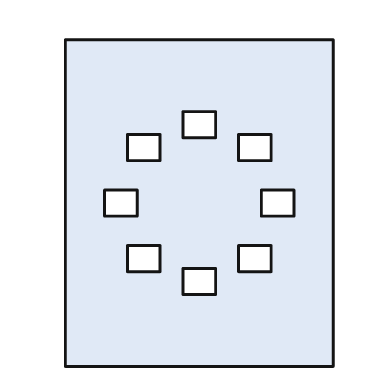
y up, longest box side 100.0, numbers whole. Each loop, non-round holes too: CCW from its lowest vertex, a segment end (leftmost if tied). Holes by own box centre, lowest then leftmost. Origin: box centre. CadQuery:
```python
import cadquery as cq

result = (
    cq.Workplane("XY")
    .moveTo(-41.0, -50.0)
    .lineTo(41.0, -50.0)
    .lineTo(41.0, 50.0)
    .lineTo(-41.0, 50.0)
    .close()
    .moveTo(-5.0, -28.0)
    .lineTo(5.0, -28.0)
    .lineTo(5.0, -20.0)
    .lineTo(-5.0, -20.0)
    .close()
    .moveTo(-22.0, -21.0)
    .lineTo(-12.0, -21.0)
    .lineTo(-12.0, -13.0)
    .lineTo(-22.0, -13.0)
    .close()
    .moveTo(12.0, -21.0)
    .lineTo(22.0, -21.0)
    .lineTo(22.0, -13.0)
    .lineTo(12.0, -13.0)
    .close()
    .moveTo(-29.0, -4.0)
    .lineTo(-19.0, -4.0)
    .lineTo(-19.0, 4.0)
    .lineTo(-29.0, 4.0)
    .close()
    .moveTo(19.0, -4.0)
    .lineTo(29.0, -4.0)
    .lineTo(29.0, 4.0)
    .lineTo(19.0, 4.0)
    .close()
    .moveTo(-22.0, 13.0)
    .lineTo(-12.0, 13.0)
    .lineTo(-12.0, 21.0)
    .lineTo(-22.0, 21.0)
    .close()
    .moveTo(12.0, 13.0)
    .lineTo(22.0, 13.0)
    .lineTo(22.0, 21.0)
    .lineTo(12.0, 21.0)
    .close()
    .moveTo(-5.0, 20.0)
    .lineTo(5.0, 20.0)
    .lineTo(5.0, 28.0)
    .lineTo(-5.0, 28.0)
    .close()
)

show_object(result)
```